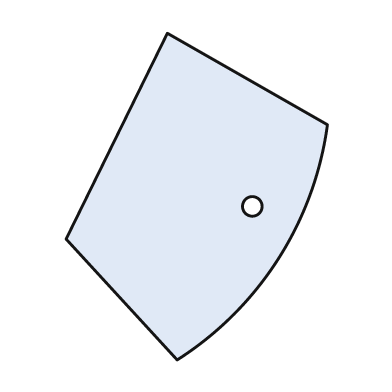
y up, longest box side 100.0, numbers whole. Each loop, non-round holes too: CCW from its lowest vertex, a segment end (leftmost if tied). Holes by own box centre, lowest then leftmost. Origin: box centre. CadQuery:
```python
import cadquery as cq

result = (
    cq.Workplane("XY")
    .moveTo(-6.0, -50.0)
    .threePointArc((25.0, -19.0), (40.0, 22.0))
    .lineTo(-9.0, 50.0)
    .lineTo(-40.0, -13.0)
    .close()
    .moveTo(17.0, -3.0)
    .circle(3.0)
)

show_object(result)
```